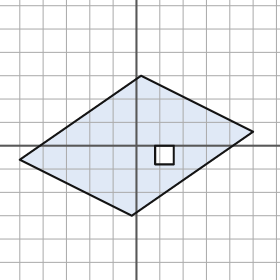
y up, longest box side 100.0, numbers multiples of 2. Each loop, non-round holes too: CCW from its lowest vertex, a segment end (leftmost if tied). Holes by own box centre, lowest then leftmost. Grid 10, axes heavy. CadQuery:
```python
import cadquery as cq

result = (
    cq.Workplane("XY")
    .moveTo(-2.0, -30.0)
    .lineTo(50.0, 6.0)
    .lineTo(2.0, 30.0)
    .lineTo(-50.0, -6.0)
    .close()
    .moveTo(8.0, -8.0)
    .lineTo(16.0, -8.0)
    .lineTo(16.0, 0.0)
    .lineTo(8.0, 0.0)
    .close()
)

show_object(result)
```